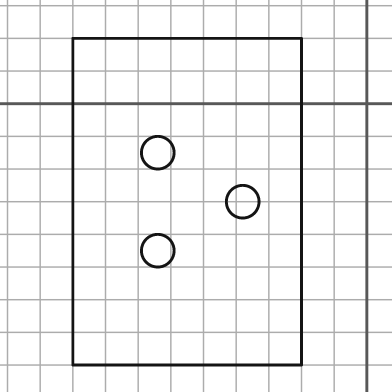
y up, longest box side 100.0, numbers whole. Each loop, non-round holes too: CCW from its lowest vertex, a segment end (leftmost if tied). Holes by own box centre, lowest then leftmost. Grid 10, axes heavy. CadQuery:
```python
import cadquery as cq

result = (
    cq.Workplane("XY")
    .moveTo(-90.0, -80.0)
    .lineTo(-20.0, -80.0)
    .lineTo(-20.0, 20.0)
    .lineTo(-90.0, 20.0)
    .close()
    .moveTo(-64.0, -45.0)
    .circle(5.0)
    .moveTo(-38.0, -30.0)
    .circle(5.0)
    .moveTo(-64.0, -15.0)
    .circle(5.0)
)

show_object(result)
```